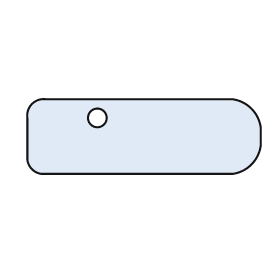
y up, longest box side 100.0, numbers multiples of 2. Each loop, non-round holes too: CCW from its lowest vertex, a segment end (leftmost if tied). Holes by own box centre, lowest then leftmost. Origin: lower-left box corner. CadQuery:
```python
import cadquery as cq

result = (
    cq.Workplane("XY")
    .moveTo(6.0, 0.0)
    .lineTo(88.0, 0.0)
    .threePointArc((96.0, 4.0), (100.0, 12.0))
    .lineTo(100.0, 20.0)
    .threePointArc((96.0, 28.0), (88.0, 32.0))
    .lineTo(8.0, 32.0)
    .threePointArc((2.0, 30.0), (0.0, 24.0))
    .lineTo(0.0, 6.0)
    .threePointArc((2.0, 2.0), (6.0, 0.0))
    .close()
    .moveTo(30.0, 24.0)
    .circle(4.0)
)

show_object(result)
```